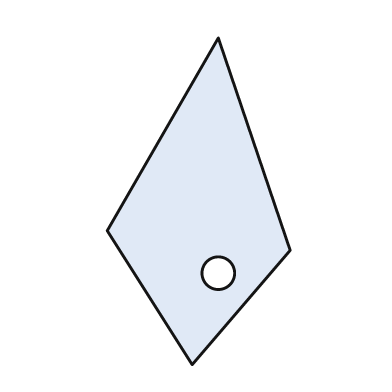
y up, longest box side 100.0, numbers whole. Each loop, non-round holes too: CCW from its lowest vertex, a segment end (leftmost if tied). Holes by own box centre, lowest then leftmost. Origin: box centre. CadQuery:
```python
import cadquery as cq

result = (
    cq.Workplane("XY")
    .moveTo(-2.0, -50.0)
    .lineTo(28.0, -15.0)
    .lineTo(6.0, 50.0)
    .lineTo(-28.0, -9.0)
    .close()
    .moveTo(6.0, -22.0)
    .circle(5.0)
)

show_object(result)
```